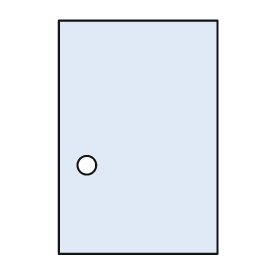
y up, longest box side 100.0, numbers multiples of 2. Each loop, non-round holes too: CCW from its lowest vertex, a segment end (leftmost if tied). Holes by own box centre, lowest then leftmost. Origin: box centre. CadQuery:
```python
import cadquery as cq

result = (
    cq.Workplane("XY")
    .moveTo(-34.0, -50.0)
    .lineTo(34.0, -50.0)
    .lineTo(34.0, 50.0)
    .lineTo(-34.0, 50.0)
    .close()
    .moveTo(-22.0, -12.0)
    .circle(4.0)
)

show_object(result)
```